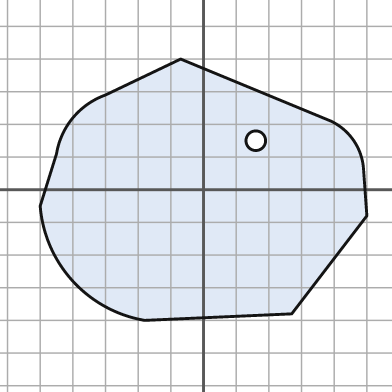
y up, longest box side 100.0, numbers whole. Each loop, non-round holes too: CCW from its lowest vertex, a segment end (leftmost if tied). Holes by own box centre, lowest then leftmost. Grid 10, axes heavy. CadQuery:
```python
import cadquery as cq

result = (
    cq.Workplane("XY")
    .moveTo(-18.0, -40.0)
    .lineTo(27.0, -38.0)
    .lineTo(50.0, -8.0)
    .lineTo(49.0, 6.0)
    .threePointArc((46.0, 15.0), (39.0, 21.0))
    .lineTo(-7.0, 40.0)
    .lineTo(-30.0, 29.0)
    .threePointArc((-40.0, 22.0), (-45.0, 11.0))
    .lineTo(-50.0, -5.0)
    .threePointArc((-40.0, -28.0), (-18.0, -40.0))
    .close()
    .moveTo(16.0, 15.0)
    .circle(3.0)
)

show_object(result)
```